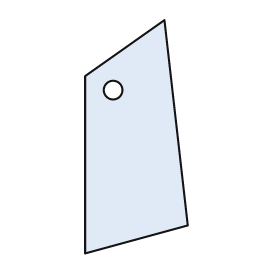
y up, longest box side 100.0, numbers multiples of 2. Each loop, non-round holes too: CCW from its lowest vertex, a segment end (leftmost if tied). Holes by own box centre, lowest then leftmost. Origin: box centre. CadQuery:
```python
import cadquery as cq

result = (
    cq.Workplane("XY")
    .moveTo(-22.0, -50.0)
    .lineTo(22.0, -38.0)
    .lineTo(12.0, 50.0)
    .lineTo(-22.0, 26.0)
    .close()
    .moveTo(-10.0, 20.0)
    .circle(4.0)
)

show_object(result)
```